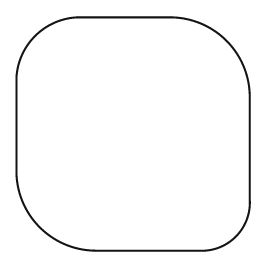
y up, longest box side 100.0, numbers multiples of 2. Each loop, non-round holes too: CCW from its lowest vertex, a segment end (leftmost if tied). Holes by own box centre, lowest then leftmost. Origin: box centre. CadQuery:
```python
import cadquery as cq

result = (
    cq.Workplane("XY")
    .moveTo(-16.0, -50.0)
    .lineTo(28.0, -50.0)
    .threePointArc((44.0, -44.0), (50.0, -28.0))
    .lineTo(50.0, 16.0)
    .threePointArc((40.0, 40.0), (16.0, 50.0))
    .lineTo(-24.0, 50.0)
    .threePointArc((-42.0, 42.0), (-50.0, 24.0))
    .lineTo(-50.0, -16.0)
    .threePointArc((-40.0, -40.0), (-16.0, -50.0))
    .close()
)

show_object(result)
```